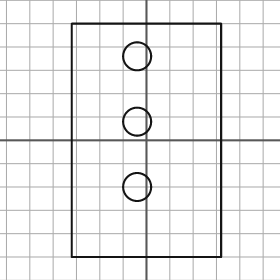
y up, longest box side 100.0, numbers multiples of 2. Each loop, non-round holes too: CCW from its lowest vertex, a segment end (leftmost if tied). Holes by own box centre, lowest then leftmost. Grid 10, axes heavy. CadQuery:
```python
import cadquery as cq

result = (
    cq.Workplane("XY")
    .moveTo(-32.0, -50.0)
    .lineTo(32.0, -50.0)
    .lineTo(32.0, 50.0)
    .lineTo(-32.0, 50.0)
    .close()
    .moveTo(-4.0, -20.0)
    .circle(6.0)
    .moveTo(-4.0, 8.0)
    .circle(6.0)
    .moveTo(-4.0, 36.0)
    .circle(6.0)
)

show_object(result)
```